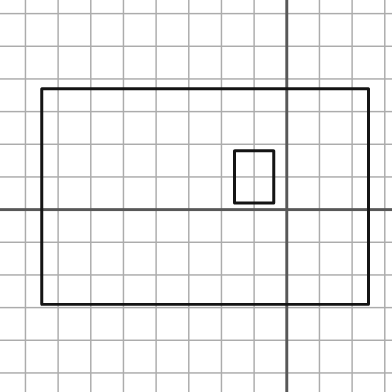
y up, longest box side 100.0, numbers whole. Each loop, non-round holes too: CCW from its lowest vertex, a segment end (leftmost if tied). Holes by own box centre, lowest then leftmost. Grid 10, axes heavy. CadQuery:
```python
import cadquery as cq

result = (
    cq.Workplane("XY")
    .moveTo(-75.0, -29.0)
    .lineTo(25.0, -29.0)
    .lineTo(25.0, 37.0)
    .lineTo(-75.0, 37.0)
    .close()
    .moveTo(-16.0, 2.0)
    .lineTo(-4.0, 2.0)
    .lineTo(-4.0, 18.0)
    .lineTo(-16.0, 18.0)
    .close()
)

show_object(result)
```